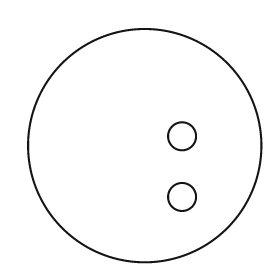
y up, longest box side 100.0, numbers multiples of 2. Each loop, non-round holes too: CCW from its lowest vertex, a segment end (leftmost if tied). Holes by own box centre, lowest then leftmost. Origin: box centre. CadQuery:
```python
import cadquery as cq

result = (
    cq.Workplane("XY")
    .moveTo(0.0, 0.0)
    .circle(50.0)
    .moveTo(16.0, -22.0)
    .circle(6.0)
    .moveTo(16.0, 4.0)
    .circle(6.0)
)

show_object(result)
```